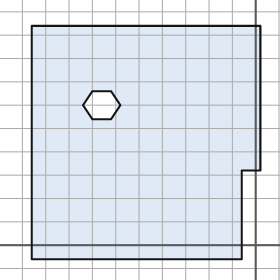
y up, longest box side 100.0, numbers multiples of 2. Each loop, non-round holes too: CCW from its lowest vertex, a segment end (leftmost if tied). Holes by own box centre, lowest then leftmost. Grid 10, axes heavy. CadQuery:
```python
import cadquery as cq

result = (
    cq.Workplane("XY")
    .moveTo(-96.0, -6.0)
    .lineTo(-6.0, -6.0)
    .lineTo(-6.0, 32.0)
    .lineTo(2.0, 32.0)
    .lineTo(2.0, 94.0)
    .lineTo(-96.0, 94.0)
    .close()
    .moveTo(-70.0, 54.0)
    .lineTo(-62.0, 54.0)
    .lineTo(-58.0, 60.0)
    .lineTo(-62.0, 66.0)
    .lineTo(-70.0, 66.0)
    .lineTo(-74.0, 60.0)
    .close()
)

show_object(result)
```